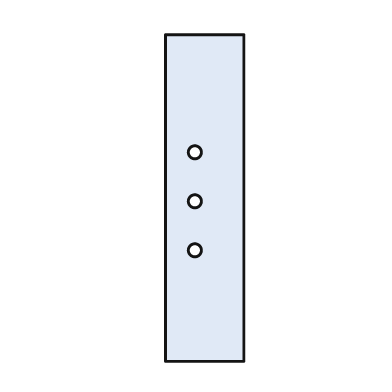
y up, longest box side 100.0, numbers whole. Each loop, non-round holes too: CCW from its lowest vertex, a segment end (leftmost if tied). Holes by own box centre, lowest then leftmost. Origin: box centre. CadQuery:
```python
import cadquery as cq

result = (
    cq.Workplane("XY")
    .moveTo(-12.0, -50.0)
    .lineTo(12.0, -50.0)
    .lineTo(12.0, 50.0)
    .lineTo(-12.0, 50.0)
    .close()
    .moveTo(-3.0, -16.0)
    .circle(2.0)
    .moveTo(-3.0, -1.0)
    .circle(2.0)
    .moveTo(-3.0, 14.0)
    .circle(2.0)
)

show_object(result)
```